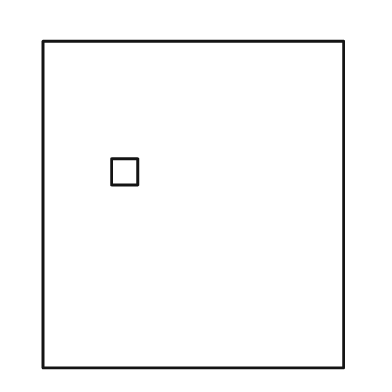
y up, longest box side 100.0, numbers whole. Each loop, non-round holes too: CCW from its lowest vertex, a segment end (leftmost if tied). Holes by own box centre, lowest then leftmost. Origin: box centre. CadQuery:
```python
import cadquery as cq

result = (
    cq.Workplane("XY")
    .moveTo(-46.0, -50.0)
    .lineTo(46.0, -50.0)
    .lineTo(46.0, 50.0)
    .lineTo(-46.0, 50.0)
    .close()
    .moveTo(-25.0, 6.0)
    .lineTo(-17.0, 6.0)
    .lineTo(-17.0, 14.0)
    .lineTo(-25.0, 14.0)
    .close()
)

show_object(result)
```